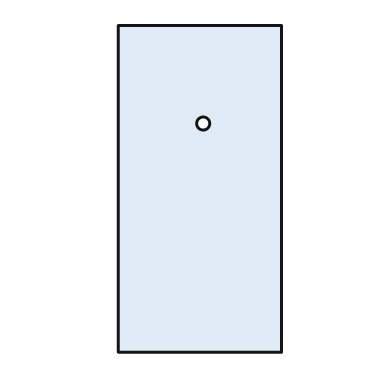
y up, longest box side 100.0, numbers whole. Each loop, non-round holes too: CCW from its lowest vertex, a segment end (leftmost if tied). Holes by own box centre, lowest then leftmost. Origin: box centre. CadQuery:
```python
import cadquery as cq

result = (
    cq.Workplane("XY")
    .moveTo(-25.0, -50.0)
    .lineTo(25.0, -50.0)
    .lineTo(25.0, 50.0)
    .lineTo(-25.0, 50.0)
    .close()
    .moveTo(1.0, 20.0)
    .circle(2.0)
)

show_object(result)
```